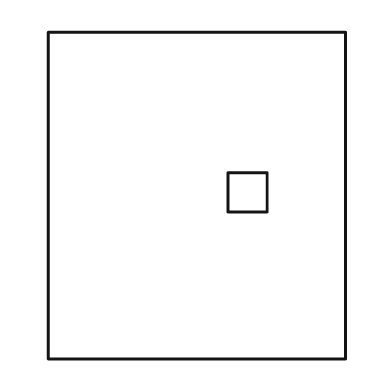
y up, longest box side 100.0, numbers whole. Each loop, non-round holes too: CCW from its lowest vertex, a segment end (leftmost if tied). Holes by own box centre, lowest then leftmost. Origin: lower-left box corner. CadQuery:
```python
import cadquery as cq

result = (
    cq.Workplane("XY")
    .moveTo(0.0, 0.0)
    .lineTo(91.0, 0.0)
    .lineTo(91.0, 100.0)
    .lineTo(0.0, 100.0)
    .close()
    .moveTo(55.0, 45.0)
    .lineTo(67.0, 45.0)
    .lineTo(67.0, 57.0)
    .lineTo(55.0, 57.0)
    .close()
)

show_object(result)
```